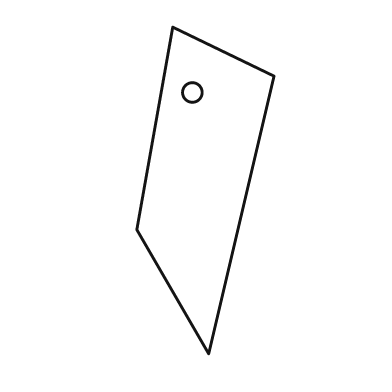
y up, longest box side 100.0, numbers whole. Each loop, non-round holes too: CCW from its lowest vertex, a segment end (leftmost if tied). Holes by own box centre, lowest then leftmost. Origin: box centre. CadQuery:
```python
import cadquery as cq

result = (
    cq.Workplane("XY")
    .moveTo(1.0, -50.0)
    .lineTo(21.0, 35.0)
    .lineTo(-10.0, 50.0)
    .lineTo(-21.0, -12.0)
    .close()
    .moveTo(-4.0, 30.0)
    .circle(3.0)
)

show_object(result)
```